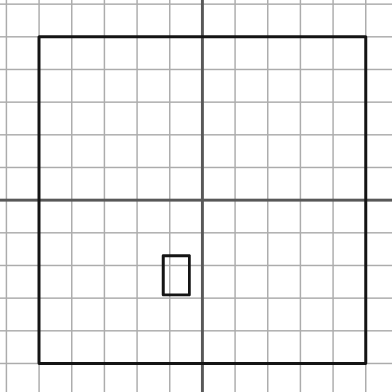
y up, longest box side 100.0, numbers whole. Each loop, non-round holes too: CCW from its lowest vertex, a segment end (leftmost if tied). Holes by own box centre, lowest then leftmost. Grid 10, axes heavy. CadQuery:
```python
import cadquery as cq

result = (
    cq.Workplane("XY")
    .moveTo(-50.0, -50.0)
    .lineTo(50.0, -50.0)
    .lineTo(50.0, 50.0)
    .lineTo(-50.0, 50.0)
    .close()
    .moveTo(-12.0, -29.0)
    .lineTo(-4.0, -29.0)
    .lineTo(-4.0, -17.0)
    .lineTo(-12.0, -17.0)
    .close()
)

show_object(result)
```